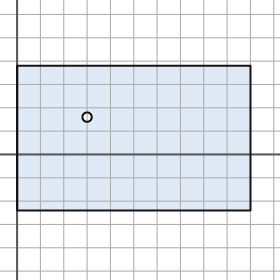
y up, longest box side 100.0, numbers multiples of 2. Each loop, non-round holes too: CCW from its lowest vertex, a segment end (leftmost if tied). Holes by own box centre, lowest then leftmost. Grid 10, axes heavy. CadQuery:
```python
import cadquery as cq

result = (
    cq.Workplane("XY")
    .moveTo(0.0, -24.0)
    .lineTo(100.0, -24.0)
    .lineTo(100.0, 38.0)
    .lineTo(0.0, 38.0)
    .close()
    .moveTo(30.0, 16.0)
    .circle(2.0)
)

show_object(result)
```